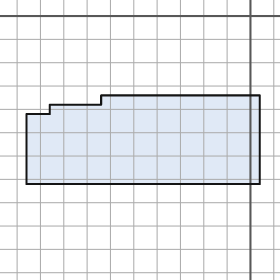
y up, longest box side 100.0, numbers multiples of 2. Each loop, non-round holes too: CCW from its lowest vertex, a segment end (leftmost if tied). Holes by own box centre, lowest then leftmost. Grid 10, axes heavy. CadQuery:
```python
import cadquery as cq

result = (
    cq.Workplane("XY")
    .moveTo(-96.0, -72.0)
    .lineTo(4.0, -72.0)
    .lineTo(4.0, -34.0)
    .lineTo(-64.0, -34.0)
    .lineTo(-64.0, -38.0)
    .lineTo(-86.0, -38.0)
    .lineTo(-86.0, -42.0)
    .lineTo(-96.0, -42.0)
    .close()
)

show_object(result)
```